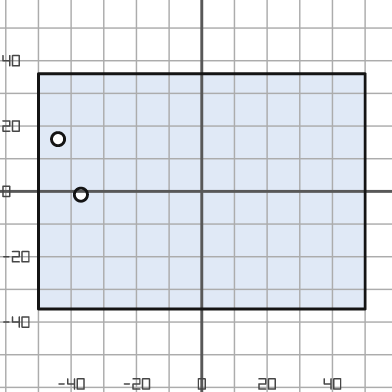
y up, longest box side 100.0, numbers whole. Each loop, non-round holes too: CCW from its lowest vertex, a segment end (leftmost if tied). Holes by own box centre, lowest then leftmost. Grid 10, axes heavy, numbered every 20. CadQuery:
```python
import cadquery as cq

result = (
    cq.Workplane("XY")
    .moveTo(-50.0, -36.0)
    .lineTo(50.0, -36.0)
    .lineTo(50.0, 36.0)
    .lineTo(-50.0, 36.0)
    .close()
    .moveTo(-37.0, -1.0)
    .circle(2.0)
    .moveTo(-44.0, 16.0)
    .circle(2.0)
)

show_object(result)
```